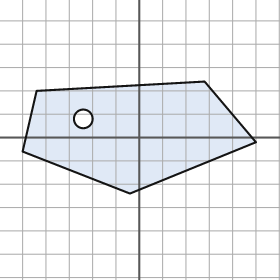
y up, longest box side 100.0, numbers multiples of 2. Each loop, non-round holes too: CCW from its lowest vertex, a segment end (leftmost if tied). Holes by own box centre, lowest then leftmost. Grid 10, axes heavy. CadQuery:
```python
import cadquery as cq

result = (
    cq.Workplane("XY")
    .moveTo(-4.0, -24.0)
    .lineTo(50.0, -2.0)
    .lineTo(28.0, 24.0)
    .lineTo(-44.0, 20.0)
    .lineTo(-50.0, -6.0)
    .close()
    .moveTo(-24.0, 8.0)
    .circle(4.0)
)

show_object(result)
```